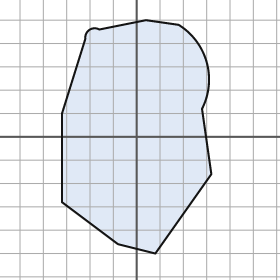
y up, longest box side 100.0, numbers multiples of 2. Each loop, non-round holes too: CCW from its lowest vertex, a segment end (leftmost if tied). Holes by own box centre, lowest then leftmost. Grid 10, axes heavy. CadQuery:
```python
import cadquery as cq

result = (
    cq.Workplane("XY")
    .moveTo(8.0, -50.0)
    .lineTo(32.0, -16.0)
    .lineTo(28.0, 12.0)
    .threePointArc((30.0, 32.0), (18.0, 48.0))
    .lineTo(4.0, 50.0)
    .lineTo(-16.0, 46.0)
    .threePointArc((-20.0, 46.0), (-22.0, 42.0))
    .lineTo(-32.0, 10.0)
    .lineTo(-32.0, -28.0)
    .lineTo(-8.0, -46.0)
    .close()
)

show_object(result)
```